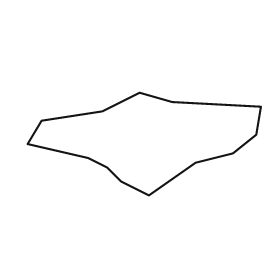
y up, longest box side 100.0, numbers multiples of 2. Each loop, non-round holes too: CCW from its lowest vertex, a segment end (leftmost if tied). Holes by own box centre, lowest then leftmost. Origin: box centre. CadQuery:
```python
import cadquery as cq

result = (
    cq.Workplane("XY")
    .moveTo(2.0, -22.0)
    .lineTo(22.0, -8.0)
    .lineTo(38.0, -4.0)
    .lineTo(48.0, 4.0)
    .lineTo(50.0, 16.0)
    .lineTo(12.0, 18.0)
    .lineTo(-2.0, 22.0)
    .lineTo(-18.0, 14.0)
    .lineTo(-44.0, 10.0)
    .lineTo(-50.0, 0.0)
    .lineTo(-24.0, -6.0)
    .lineTo(-16.0, -10.0)
    .lineTo(-10.0, -16.0)
    .close()
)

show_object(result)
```